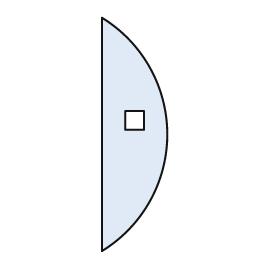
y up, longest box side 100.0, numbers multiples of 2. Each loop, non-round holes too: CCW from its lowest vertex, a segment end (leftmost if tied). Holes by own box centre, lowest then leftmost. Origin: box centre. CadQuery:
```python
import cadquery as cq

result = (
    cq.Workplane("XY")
    .moveTo(-14.0, -50.0)
    .threePointArc((14.0, 0.0), (-14.0, 50.0))
    .close()
    .moveTo(-4.0, 2.0)
    .lineTo(4.0, 2.0)
    .lineTo(4.0, 10.0)
    .lineTo(-4.0, 10.0)
    .close()
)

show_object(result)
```